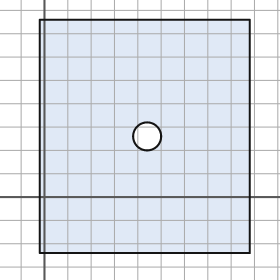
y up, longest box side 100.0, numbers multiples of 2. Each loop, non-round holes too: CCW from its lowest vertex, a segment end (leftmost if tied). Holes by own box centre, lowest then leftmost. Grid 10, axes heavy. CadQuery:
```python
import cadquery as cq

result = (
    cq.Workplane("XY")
    .moveTo(-2.0, -24.0)
    .lineTo(88.0, -24.0)
    .lineTo(88.0, 76.0)
    .lineTo(-2.0, 76.0)
    .close()
    .moveTo(44.0, 26.0)
    .circle(6.0)
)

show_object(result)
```